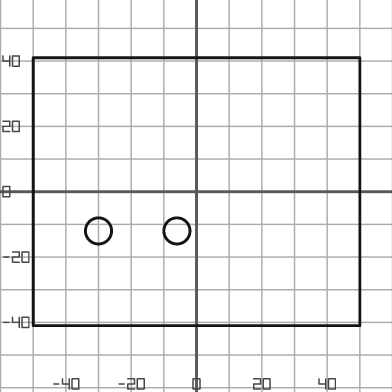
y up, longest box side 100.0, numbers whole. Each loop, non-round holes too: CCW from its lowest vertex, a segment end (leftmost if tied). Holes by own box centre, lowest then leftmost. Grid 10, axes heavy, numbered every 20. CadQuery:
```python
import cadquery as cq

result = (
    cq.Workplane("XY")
    .moveTo(-50.0, -41.0)
    .lineTo(50.0, -41.0)
    .lineTo(50.0, 41.0)
    .lineTo(-50.0, 41.0)
    .close()
    .moveTo(-30.0, -12.0)
    .circle(4.0)
    .moveTo(-6.0, -12.0)
    .circle(4.0)
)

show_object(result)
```